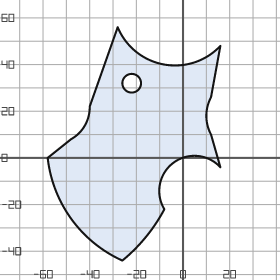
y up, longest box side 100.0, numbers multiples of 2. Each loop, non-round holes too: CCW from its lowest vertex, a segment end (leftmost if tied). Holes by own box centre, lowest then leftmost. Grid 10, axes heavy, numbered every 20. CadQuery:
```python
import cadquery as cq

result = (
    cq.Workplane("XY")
    .moveTo(-26.0, -44.0)
    .threePointArc((-16.0, -34.0), (-8.0, -22.0))
    .threePointArc((-4.0, -2.0), (16.0, -4.0))
    .lineTo(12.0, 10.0)
    .threePointArc((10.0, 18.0), (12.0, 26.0))
    .lineTo(16.0, 48.0)
    .threePointArc((-8.0, 40.0), (-28.0, 56.0))
    .lineTo(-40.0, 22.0)
    .threePointArc((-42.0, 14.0), (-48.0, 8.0))
    .lineTo(-58.0, 0.0)
    .threePointArc((-48.0, -26.0), (-26.0, -44.0))
    .close()
    .moveTo(-22.0, 32.0)
    .circle(4.0)
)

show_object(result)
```